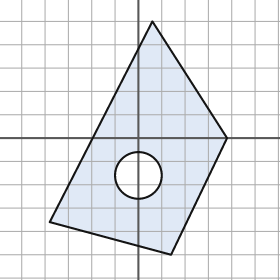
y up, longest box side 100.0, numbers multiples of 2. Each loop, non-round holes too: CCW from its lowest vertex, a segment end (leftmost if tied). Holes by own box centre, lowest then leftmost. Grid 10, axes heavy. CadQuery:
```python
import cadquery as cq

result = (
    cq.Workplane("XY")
    .moveTo(14.0, -50.0)
    .lineTo(38.0, 0.0)
    .lineTo(6.0, 50.0)
    .lineTo(-38.0, -36.0)
    .close()
    .moveTo(0.0, -16.0)
    .circle(10.0)
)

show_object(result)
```